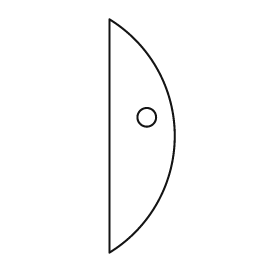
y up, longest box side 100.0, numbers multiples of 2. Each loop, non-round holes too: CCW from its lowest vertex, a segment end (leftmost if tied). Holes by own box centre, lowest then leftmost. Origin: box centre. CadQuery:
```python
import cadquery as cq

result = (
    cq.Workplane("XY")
    .moveTo(-14.0, -50.0)
    .threePointArc((14.0, 0.0), (-14.0, 50.0))
    .close()
    .moveTo(2.0, 8.0)
    .circle(4.0)
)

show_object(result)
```